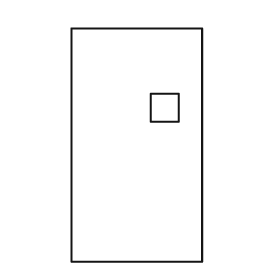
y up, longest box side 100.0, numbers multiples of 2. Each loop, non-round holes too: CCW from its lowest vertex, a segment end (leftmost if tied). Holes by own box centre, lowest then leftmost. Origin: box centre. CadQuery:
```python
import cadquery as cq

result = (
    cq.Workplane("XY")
    .moveTo(-28.0, -50.0)
    .lineTo(28.0, -50.0)
    .lineTo(28.0, 50.0)
    .lineTo(-28.0, 50.0)
    .close()
    .moveTo(6.0, 10.0)
    .lineTo(18.0, 10.0)
    .lineTo(18.0, 22.0)
    .lineTo(6.0, 22.0)
    .close()
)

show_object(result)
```